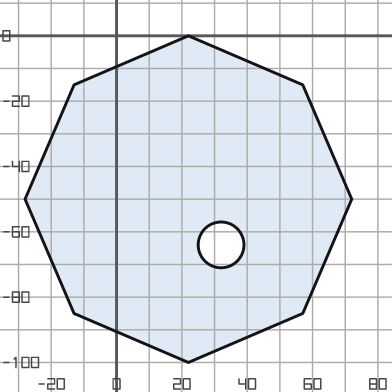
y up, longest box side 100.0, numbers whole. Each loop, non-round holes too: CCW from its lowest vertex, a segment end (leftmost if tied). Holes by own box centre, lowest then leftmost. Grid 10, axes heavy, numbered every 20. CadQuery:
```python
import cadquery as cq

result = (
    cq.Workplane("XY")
    .moveTo(22.0, -100.0)
    .lineTo(57.0, -85.0)
    .lineTo(72.0, -50.0)
    .lineTo(57.0, -15.0)
    .lineTo(22.0, 0.0)
    .lineTo(-13.0, -15.0)
    .lineTo(-28.0, -50.0)
    .lineTo(-13.0, -85.0)
    .close()
    .moveTo(32.0, -64.0)
    .circle(7.0)
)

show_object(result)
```